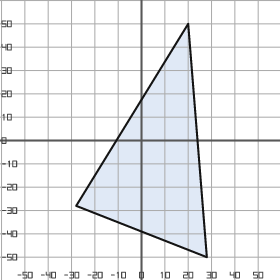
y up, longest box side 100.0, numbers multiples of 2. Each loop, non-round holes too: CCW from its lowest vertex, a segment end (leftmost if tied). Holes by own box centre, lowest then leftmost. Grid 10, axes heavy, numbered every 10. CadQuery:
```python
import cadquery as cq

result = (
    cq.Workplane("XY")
    .moveTo(28.0, -50.0)
    .lineTo(20.0, 50.0)
    .lineTo(-28.0, -28.0)
    .close()
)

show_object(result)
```